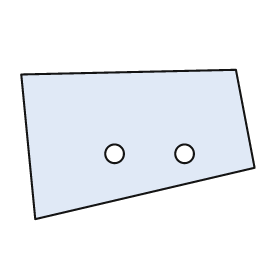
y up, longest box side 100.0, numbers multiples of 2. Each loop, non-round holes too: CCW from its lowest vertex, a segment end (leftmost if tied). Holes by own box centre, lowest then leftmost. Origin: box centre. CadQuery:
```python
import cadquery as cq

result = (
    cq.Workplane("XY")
    .moveTo(-44.0, -32.0)
    .lineTo(50.0, -10.0)
    .lineTo(42.0, 32.0)
    .lineTo(-50.0, 30.0)
    .close()
    .moveTo(-10.0, -4.0)
    .circle(4.0)
    .moveTo(20.0, -4.0)
    .circle(4.0)
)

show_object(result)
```